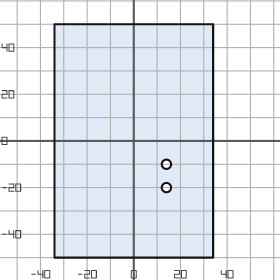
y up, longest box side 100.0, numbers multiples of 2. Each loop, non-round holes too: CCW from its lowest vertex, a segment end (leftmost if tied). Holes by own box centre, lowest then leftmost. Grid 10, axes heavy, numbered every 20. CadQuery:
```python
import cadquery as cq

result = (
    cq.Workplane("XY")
    .moveTo(-34.0, -50.0)
    .lineTo(34.0, -50.0)
    .lineTo(34.0, 50.0)
    .lineTo(-34.0, 50.0)
    .close()
    .moveTo(14.0, -20.0)
    .circle(2.0)
    .moveTo(14.0, -10.0)
    .circle(2.0)
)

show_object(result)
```